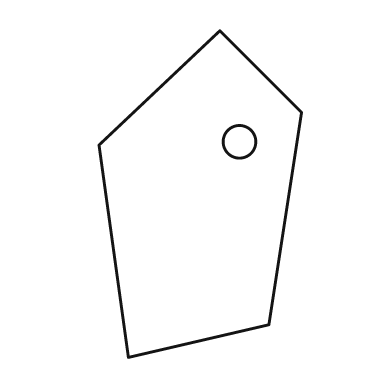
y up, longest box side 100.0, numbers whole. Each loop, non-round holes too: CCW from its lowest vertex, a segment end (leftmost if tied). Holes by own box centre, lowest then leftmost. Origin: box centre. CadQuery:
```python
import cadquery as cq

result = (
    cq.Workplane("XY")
    .moveTo(-22.0, -50.0)
    .lineTo(21.0, -40.0)
    .lineTo(31.0, 25.0)
    .lineTo(6.0, 50.0)
    .lineTo(-31.0, 15.0)
    .close()
    .moveTo(12.0, 16.0)
    .circle(5.0)
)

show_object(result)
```